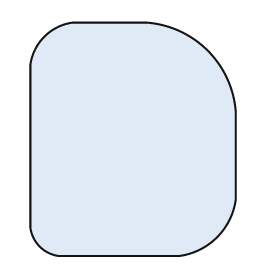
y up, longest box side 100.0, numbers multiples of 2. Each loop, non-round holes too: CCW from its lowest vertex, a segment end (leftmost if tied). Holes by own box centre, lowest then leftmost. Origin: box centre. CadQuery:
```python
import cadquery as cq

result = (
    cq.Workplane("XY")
    .moveTo(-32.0, -50.0)
    .lineTo(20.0, -50.0)
    .threePointArc((36.0, -42.0), (44.0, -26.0))
    .lineTo(44.0, 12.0)
    .threePointArc((32.0, 38.0), (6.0, 50.0))
    .lineTo(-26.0, 50.0)
    .threePointArc((-38.0, 44.0), (-44.0, 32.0))
    .lineTo(-44.0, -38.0)
    .threePointArc((-40.0, -46.0), (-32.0, -50.0))
    .close()
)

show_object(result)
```